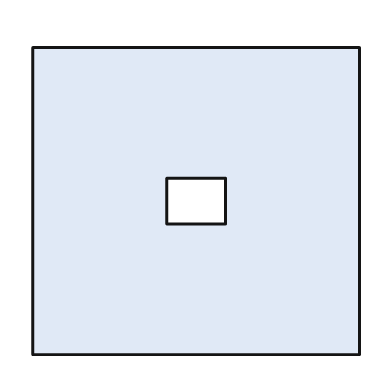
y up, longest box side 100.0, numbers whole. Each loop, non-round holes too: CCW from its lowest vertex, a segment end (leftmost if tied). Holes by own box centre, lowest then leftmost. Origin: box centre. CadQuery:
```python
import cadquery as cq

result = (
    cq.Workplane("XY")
    .moveTo(-50.0, -47.0)
    .lineTo(50.0, -47.0)
    .lineTo(50.0, 47.0)
    .lineTo(-50.0, 47.0)
    .close()
    .moveTo(-9.0, -7.0)
    .lineTo(9.0, -7.0)
    .lineTo(9.0, 7.0)
    .lineTo(-9.0, 7.0)
    .close()
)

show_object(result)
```